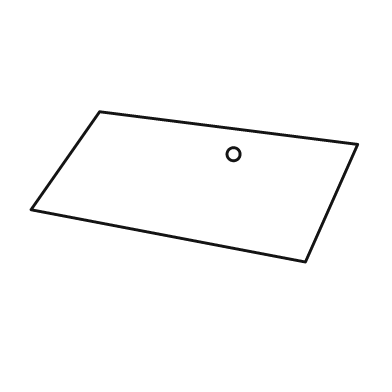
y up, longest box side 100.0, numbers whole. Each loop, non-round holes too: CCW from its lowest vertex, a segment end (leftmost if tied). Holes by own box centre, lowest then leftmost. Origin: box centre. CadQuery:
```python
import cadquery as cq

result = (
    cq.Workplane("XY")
    .moveTo(34.0, -23.0)
    .lineTo(50.0, 13.0)
    .lineTo(-29.0, 23.0)
    .lineTo(-50.0, -7.0)
    .close()
    .moveTo(12.0, 10.0)
    .circle(2.0)
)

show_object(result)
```